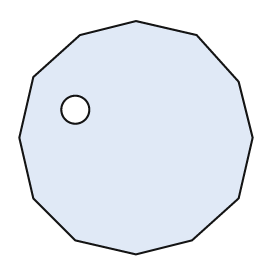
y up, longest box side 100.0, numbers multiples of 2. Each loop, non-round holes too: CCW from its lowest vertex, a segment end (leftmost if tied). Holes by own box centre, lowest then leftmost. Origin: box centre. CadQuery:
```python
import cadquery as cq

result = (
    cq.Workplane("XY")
    .moveTo(0.0, -50.0)
    .lineTo(24.0, -44.0)
    .lineTo(44.0, -26.0)
    .lineTo(50.0, 0.0)
    .lineTo(44.0, 24.0)
    .lineTo(26.0, 44.0)
    .lineTo(0.0, 50.0)
    .lineTo(-24.0, 44.0)
    .lineTo(-44.0, 26.0)
    .lineTo(-50.0, 0.0)
    .lineTo(-44.0, -26.0)
    .lineTo(-26.0, -44.0)
    .close()
    .moveTo(-26.0, 12.0)
    .circle(6.0)
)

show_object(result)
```